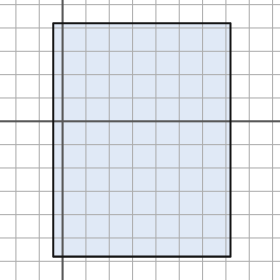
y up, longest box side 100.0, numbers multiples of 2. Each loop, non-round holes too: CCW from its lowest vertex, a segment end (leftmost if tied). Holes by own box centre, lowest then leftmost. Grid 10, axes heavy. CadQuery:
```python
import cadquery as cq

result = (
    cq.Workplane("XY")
    .moveTo(-4.0, -58.0)
    .lineTo(72.0, -58.0)
    .lineTo(72.0, 42.0)
    .lineTo(-4.0, 42.0)
    .close()
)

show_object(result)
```